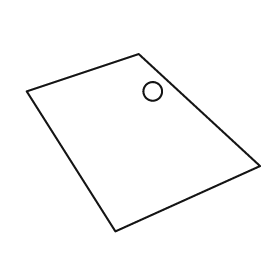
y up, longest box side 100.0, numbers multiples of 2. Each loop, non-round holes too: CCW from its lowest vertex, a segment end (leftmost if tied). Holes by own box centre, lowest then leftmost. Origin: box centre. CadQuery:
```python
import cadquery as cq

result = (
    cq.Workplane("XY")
    .moveTo(-12.0, -38.0)
    .lineTo(50.0, -10.0)
    .lineTo(-2.0, 38.0)
    .lineTo(-50.0, 22.0)
    .close()
    .moveTo(4.0, 22.0)
    .circle(4.0)
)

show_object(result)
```